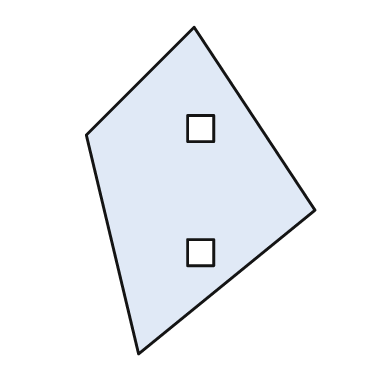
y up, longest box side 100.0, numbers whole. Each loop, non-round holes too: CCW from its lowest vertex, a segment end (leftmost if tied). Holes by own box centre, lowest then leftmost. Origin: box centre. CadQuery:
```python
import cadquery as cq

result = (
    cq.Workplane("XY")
    .moveTo(-19.0, -50.0)
    .lineTo(35.0, -6.0)
    .lineTo(-2.0, 50.0)
    .lineTo(-35.0, 17.0)
    .close()
    .moveTo(-4.0, -23.0)
    .lineTo(4.0, -23.0)
    .lineTo(4.0, -15.0)
    .lineTo(-4.0, -15.0)
    .close()
    .moveTo(-4.0, 15.0)
    .lineTo(4.0, 15.0)
    .lineTo(4.0, 23.0)
    .lineTo(-4.0, 23.0)
    .close()
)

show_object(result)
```